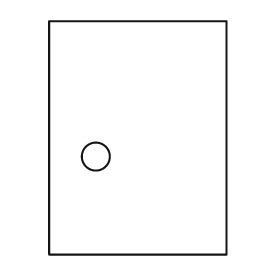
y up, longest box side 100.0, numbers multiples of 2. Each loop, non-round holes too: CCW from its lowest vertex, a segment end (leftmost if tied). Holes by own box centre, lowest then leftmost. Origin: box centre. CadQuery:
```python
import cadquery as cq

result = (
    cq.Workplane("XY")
    .moveTo(-38.0, -50.0)
    .lineTo(38.0, -50.0)
    .lineTo(38.0, 50.0)
    .lineTo(-38.0, 50.0)
    .close()
    .moveTo(-18.0, -8.0)
    .circle(6.0)
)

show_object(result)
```